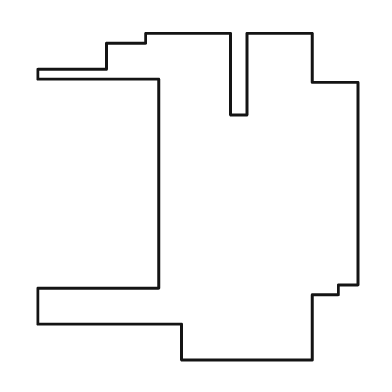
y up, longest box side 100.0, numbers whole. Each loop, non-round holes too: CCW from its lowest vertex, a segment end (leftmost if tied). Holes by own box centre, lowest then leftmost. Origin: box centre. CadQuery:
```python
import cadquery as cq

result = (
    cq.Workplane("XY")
    .moveTo(-5.0, -50.0)
    .lineTo(35.0, -50.0)
    .lineTo(35.0, -30.0)
    .lineTo(43.0, -30.0)
    .lineTo(43.0, -27.0)
    .lineTo(49.0, -27.0)
    .lineTo(49.0, 35.0)
    .lineTo(35.0, 35.0)
    .lineTo(35.0, 50.0)
    .lineTo(15.0, 50.0)
    .lineTo(15.0, 25.0)
    .lineTo(10.0, 25.0)
    .lineTo(10.0, 50.0)
    .lineTo(-16.0, 50.0)
    .lineTo(-16.0, 47.0)
    .lineTo(-28.0, 47.0)
    .lineTo(-28.0, 39.0)
    .lineTo(-49.0, 39.0)
    .lineTo(-49.0, 36.0)
    .lineTo(-12.0, 36.0)
    .lineTo(-12.0, -28.0)
    .lineTo(-49.0, -28.0)
    .lineTo(-49.0, -39.0)
    .lineTo(-5.0, -39.0)
    .close()
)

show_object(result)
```